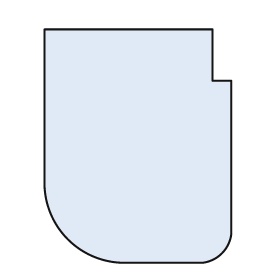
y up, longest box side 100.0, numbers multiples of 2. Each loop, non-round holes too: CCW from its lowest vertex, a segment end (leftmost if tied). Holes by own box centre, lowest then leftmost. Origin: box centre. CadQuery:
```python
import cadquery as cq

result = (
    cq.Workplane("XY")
    .moveTo(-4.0, -50.0)
    .lineTo(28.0, -50.0)
    .threePointArc((36.0, -46.0), (40.0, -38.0))
    .lineTo(40.0, 28.0)
    .lineTo(32.0, 28.0)
    .lineTo(32.0, 50.0)
    .lineTo(-40.0, 50.0)
    .lineTo(-40.0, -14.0)
    .threePointArc((-30.0, -40.0), (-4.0, -50.0))
    .close()
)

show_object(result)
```